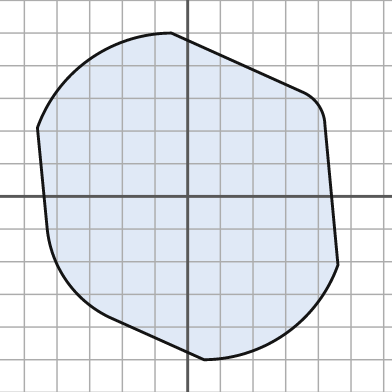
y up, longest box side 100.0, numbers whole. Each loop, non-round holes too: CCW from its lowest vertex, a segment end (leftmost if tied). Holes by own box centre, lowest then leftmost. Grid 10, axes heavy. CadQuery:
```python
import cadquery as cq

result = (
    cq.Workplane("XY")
    .moveTo(5.0, -50.0)
    .threePointArc((30.0, -42.0), (46.0, -21.0))
    .lineTo(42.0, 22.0)
    .threePointArc((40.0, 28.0), (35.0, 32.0))
    .lineTo(-5.0, 50.0)
    .threePointArc((-30.0, 42.0), (-46.0, 21.0))
    .lineTo(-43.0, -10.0)
    .threePointArc((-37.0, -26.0), (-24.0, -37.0))
    .close()
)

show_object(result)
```